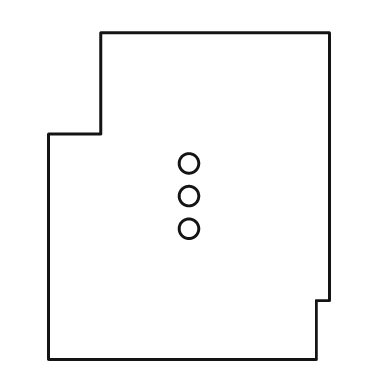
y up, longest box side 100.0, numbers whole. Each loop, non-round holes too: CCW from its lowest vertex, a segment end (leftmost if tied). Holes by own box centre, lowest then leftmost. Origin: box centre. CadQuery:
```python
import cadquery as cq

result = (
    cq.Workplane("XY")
    .moveTo(-43.0, -50.0)
    .lineTo(39.0, -50.0)
    .lineTo(39.0, -32.0)
    .lineTo(43.0, -32.0)
    .lineTo(43.0, 50.0)
    .lineTo(-27.0, 50.0)
    .lineTo(-27.0, 19.0)
    .lineTo(-43.0, 19.0)
    .close()
    .moveTo(0.0, -10.0)
    .circle(3.0)
    .moveTo(0.0, 0.0)
    .circle(3.0)
    .moveTo(0.0, 10.0)
    .circle(3.0)
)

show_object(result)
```